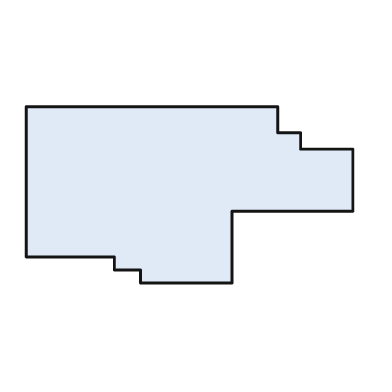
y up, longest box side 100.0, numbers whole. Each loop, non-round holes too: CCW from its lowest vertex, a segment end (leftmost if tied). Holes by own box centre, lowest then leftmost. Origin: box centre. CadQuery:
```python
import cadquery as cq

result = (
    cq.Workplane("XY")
    .moveTo(-15.0, -27.0)
    .lineTo(13.0, -27.0)
    .lineTo(13.0, -5.0)
    .lineTo(50.0, -5.0)
    .lineTo(50.0, 14.0)
    .lineTo(34.0, 14.0)
    .lineTo(34.0, 19.0)
    .lineTo(27.0, 19.0)
    .lineTo(27.0, 27.0)
    .lineTo(-50.0, 27.0)
    .lineTo(-50.0, -19.0)
    .lineTo(-23.0, -19.0)
    .lineTo(-23.0, -23.0)
    .lineTo(-15.0, -23.0)
    .close()
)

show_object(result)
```